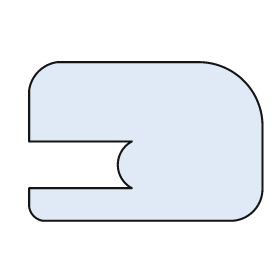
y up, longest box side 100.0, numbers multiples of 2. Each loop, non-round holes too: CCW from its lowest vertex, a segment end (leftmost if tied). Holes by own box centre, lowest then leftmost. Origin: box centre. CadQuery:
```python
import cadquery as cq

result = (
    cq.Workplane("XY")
    .moveTo(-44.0, -34.0)
    .lineTo(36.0, -34.0)
    .threePointArc((46.0, -30.0), (50.0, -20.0))
    .lineTo(50.0, 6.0)
    .threePointArc((42.0, 26.0), (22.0, 34.0))
    .lineTo(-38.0, 34.0)
    .threePointArc((-46.0, 30.0), (-50.0, 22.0))
    .lineTo(-50.0, 0.0)
    .lineTo(-6.0, 0.0)
    .threePointArc((-12.0, -10.0), (-6.0, -20.0))
    .lineTo(-50.0, -20.0)
    .lineTo(-50.0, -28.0)
    .threePointArc((-48.0, -32.0), (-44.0, -34.0))
    .close()
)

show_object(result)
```